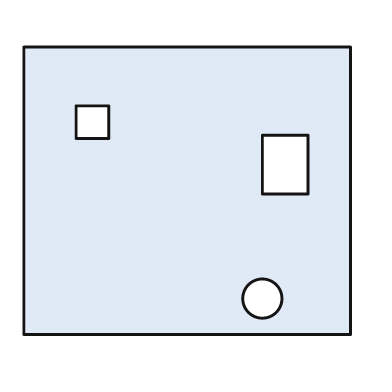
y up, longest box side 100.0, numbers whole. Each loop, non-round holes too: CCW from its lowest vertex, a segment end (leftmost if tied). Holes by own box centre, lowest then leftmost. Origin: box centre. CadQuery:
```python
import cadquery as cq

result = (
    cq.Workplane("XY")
    .moveTo(-50.0, -44.0)
    .lineTo(50.0, -44.0)
    .lineTo(50.0, 44.0)
    .lineTo(-50.0, 44.0)
    .close()
    .moveTo(23.0, -33.0)
    .circle(6.0)
    .moveTo(23.0, -1.0)
    .lineTo(37.0, -1.0)
    .lineTo(37.0, 17.0)
    .lineTo(23.0, 17.0)
    .close()
    .moveTo(-34.0, 16.0)
    .lineTo(-24.0, 16.0)
    .lineTo(-24.0, 26.0)
    .lineTo(-34.0, 26.0)
    .close()
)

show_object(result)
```